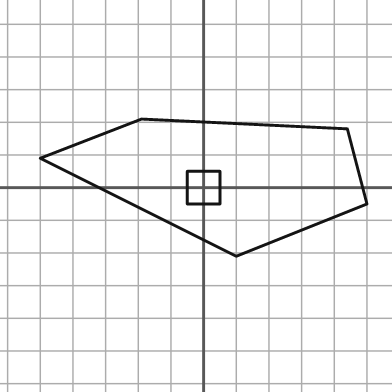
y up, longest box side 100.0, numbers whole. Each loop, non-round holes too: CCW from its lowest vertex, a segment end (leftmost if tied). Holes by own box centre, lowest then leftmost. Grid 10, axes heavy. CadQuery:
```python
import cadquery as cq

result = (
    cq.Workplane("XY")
    .moveTo(10.0, -21.0)
    .lineTo(50.0, -5.0)
    .lineTo(44.0, 18.0)
    .lineTo(-19.0, 21.0)
    .lineTo(-50.0, 9.0)
    .close()
    .moveTo(-5.0, -5.0)
    .lineTo(5.0, -5.0)
    .lineTo(5.0, 5.0)
    .lineTo(-5.0, 5.0)
    .close()
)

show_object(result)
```